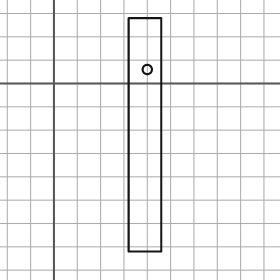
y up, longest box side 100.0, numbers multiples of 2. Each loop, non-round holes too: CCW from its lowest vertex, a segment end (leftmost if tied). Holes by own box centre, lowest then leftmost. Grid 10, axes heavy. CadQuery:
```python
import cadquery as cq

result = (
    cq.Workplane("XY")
    .moveTo(32.0, -72.0)
    .lineTo(46.0, -72.0)
    .lineTo(46.0, 28.0)
    .lineTo(32.0, 28.0)
    .close()
    .moveTo(40.0, 6.0)
    .circle(2.0)
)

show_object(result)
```